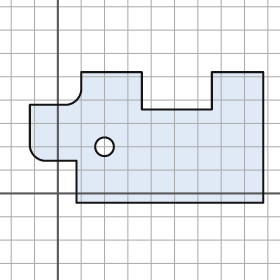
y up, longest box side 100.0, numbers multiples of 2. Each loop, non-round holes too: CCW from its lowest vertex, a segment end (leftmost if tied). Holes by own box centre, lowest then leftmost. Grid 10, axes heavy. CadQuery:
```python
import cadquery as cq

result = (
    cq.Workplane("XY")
    .moveTo(8.0, -4.0)
    .lineTo(88.0, -4.0)
    .lineTo(88.0, 52.0)
    .lineTo(66.0, 52.0)
    .lineTo(66.0, 36.0)
    .lineTo(36.0, 36.0)
    .lineTo(36.0, 52.0)
    .lineTo(10.0, 52.0)
    .lineTo(10.0, 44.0)
    .threePointArc((8.0, 40.0), (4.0, 38.0))
    .lineTo(-12.0, 38.0)
    .lineTo(-12.0, 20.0)
    .threePointArc((-10.0, 16.0), (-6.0, 14.0))
    .lineTo(8.0, 14.0)
    .close()
    .moveTo(20.0, 20.0)
    .circle(4.0)
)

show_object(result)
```